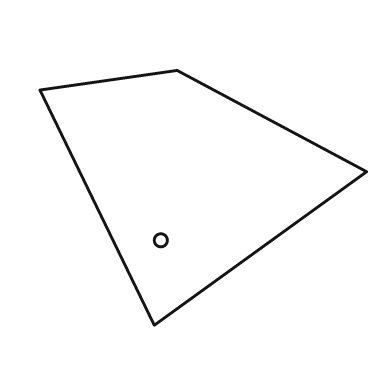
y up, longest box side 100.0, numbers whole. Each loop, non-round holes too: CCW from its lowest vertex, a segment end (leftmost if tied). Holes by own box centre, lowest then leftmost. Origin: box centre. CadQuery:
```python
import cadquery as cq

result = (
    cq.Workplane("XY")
    .moveTo(-15.0, -39.0)
    .lineTo(50.0, 8.0)
    .lineTo(-8.0, 39.0)
    .lineTo(-50.0, 33.0)
    .close()
    .moveTo(-13.0, -13.0)
    .circle(2.0)
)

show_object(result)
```